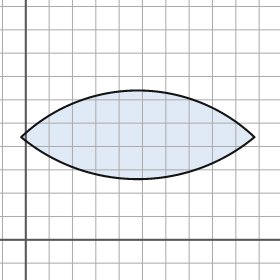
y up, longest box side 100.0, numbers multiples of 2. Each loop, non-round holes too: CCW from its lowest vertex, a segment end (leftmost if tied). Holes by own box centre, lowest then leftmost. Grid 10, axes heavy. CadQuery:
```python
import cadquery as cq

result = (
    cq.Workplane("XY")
    .moveTo(-2.0, 44.0)
    .threePointArc((48.0, 26.0), (98.0, 44.0))
    .threePointArc((48.0, 64.0), (-2.0, 44.0))
    .close()
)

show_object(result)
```